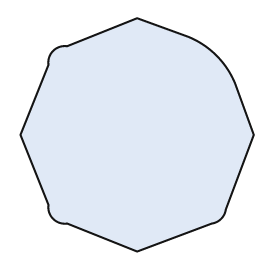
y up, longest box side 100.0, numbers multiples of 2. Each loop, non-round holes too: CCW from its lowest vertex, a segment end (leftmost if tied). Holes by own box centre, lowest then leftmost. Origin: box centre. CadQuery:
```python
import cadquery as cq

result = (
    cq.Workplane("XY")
    .moveTo(0.0, -50.0)
    .lineTo(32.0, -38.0)
    .threePointArc((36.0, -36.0), (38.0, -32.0))
    .lineTo(50.0, 0.0)
    .lineTo(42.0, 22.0)
    .threePointArc((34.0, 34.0), (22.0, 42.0))
    .lineTo(0.0, 50.0)
    .lineTo(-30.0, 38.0)
    .threePointArc((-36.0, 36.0), (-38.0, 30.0))
    .lineTo(-50.0, 0.0)
    .lineTo(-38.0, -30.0)
    .threePointArc((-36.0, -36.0), (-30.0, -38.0))
    .close()
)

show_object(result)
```